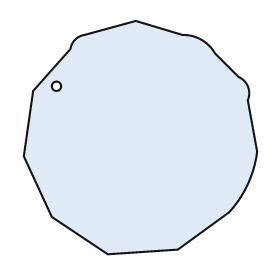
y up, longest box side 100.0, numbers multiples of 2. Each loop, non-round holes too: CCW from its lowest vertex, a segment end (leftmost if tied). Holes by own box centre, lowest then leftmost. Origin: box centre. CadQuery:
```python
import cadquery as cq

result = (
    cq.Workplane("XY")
    .moveTo(-14.0, -50.0)
    .lineTo(16.0, -48.0)
    .lineTo(38.0, -32.0)
    .threePointArc((46.0, -20.0), (50.0, -6.0))
    .lineTo(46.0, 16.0)
    .threePointArc((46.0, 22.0), (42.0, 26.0))
    .lineTo(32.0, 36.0)
    .threePointArc((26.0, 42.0), (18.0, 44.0))
    .lineTo(-2.0, 50.0)
    .lineTo(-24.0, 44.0)
    .threePointArc((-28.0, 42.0), (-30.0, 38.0))
    .lineTo(-46.0, 20.0)
    .lineTo(-50.0, -8.0)
    .lineTo(-38.0, -34.0)
    .close()
    .moveTo(-36.0, 22.0)
    .circle(2.0)
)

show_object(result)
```